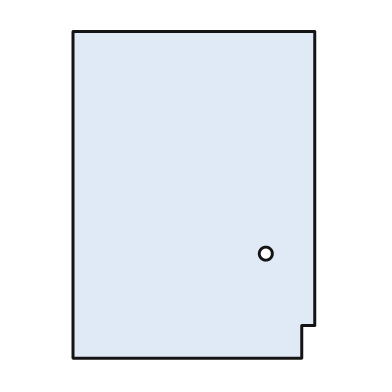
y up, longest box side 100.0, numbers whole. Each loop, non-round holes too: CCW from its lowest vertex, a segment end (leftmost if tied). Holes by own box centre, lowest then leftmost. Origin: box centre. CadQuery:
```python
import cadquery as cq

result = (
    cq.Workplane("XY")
    .moveTo(-37.0, -50.0)
    .lineTo(33.0, -50.0)
    .lineTo(33.0, -40.0)
    .lineTo(37.0, -40.0)
    .lineTo(37.0, 50.0)
    .lineTo(-37.0, 50.0)
    .close()
    .moveTo(22.0, -18.0)
    .circle(2.0)
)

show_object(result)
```